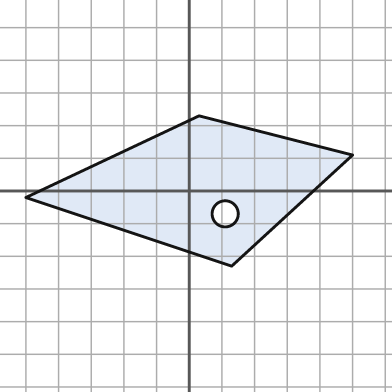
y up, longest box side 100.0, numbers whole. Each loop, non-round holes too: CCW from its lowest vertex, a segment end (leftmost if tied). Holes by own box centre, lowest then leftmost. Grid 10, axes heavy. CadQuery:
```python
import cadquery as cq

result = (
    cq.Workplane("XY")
    .moveTo(13.0, -23.0)
    .lineTo(50.0, 11.0)
    .lineTo(3.0, 23.0)
    .lineTo(-50.0, -2.0)
    .close()
    .moveTo(11.0, -7.0)
    .circle(4.0)
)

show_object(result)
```